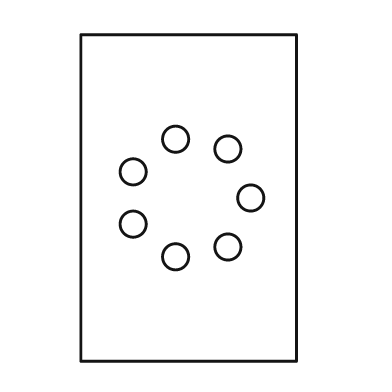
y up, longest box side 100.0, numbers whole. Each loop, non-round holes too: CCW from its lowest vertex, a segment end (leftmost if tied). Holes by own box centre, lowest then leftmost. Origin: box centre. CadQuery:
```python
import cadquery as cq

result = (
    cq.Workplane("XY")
    .moveTo(-33.0, -50.0)
    .lineTo(33.0, -50.0)
    .lineTo(33.0, 50.0)
    .lineTo(-33.0, 50.0)
    .close()
    .moveTo(-4.0, -18.0)
    .circle(4.0)
    .moveTo(12.0, -15.0)
    .circle(4.0)
    .moveTo(-17.0, -8.0)
    .circle(4.0)
    .moveTo(19.0, 0.0)
    .circle(4.0)
    .moveTo(-17.0, 8.0)
    .circle(4.0)
    .moveTo(12.0, 15.0)
    .circle(4.0)
    .moveTo(-4.0, 18.0)
    .circle(4.0)
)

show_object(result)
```